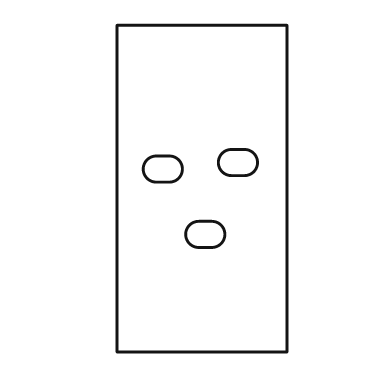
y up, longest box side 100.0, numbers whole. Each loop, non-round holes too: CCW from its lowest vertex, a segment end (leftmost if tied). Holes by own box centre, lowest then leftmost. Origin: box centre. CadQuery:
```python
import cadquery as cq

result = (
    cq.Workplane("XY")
    .moveTo(-26.0, -50.0)
    .lineTo(26.0, -50.0)
    .lineTo(26.0, 50.0)
    .lineTo(-26.0, 50.0)
    .close()
    .moveTo(-1.0, -18.0)
    .lineTo(3.0, -18.0)
    .threePointArc((7.0, -14.0), (3.0, -10.0))
    .lineTo(-1.0, -10.0)
    .threePointArc((-5.0, -14.0), (-1.0, -18.0))
    .close()
    .moveTo(-14.0, 2.0)
    .lineTo(-10.0, 2.0)
    .threePointArc((-6.0, 6.0), (-10.0, 10.0))
    .lineTo(-14.0, 10.0)
    .threePointArc((-18.0, 6.0), (-14.0, 2.0))
    .close()
    .moveTo(9.0, 4.0)
    .lineTo(13.0, 4.0)
    .threePointArc((17.0, 8.0), (13.0, 12.0))
    .lineTo(9.0, 12.0)
    .threePointArc((5.0, 8.0), (9.0, 4.0))
    .close()
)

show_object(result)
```